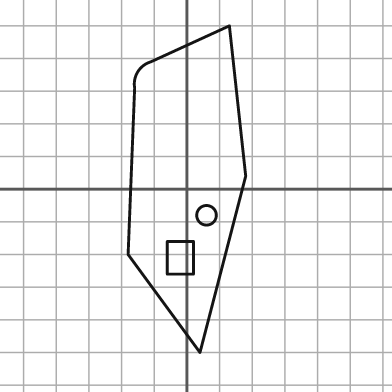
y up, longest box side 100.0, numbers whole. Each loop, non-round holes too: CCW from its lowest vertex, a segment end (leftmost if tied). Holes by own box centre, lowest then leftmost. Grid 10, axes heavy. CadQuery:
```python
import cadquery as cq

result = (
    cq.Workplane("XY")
    .moveTo(4.0, -50.0)
    .lineTo(18.0, 4.0)
    .lineTo(13.0, 50.0)
    .lineTo(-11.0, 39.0)
    .threePointArc((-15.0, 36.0), (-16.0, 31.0))
    .lineTo(-18.0, -20.0)
    .close()
    .moveTo(-6.0, -26.0)
    .lineTo(2.0, -26.0)
    .lineTo(2.0, -16.0)
    .lineTo(-6.0, -16.0)
    .close()
    .moveTo(6.0, -8.0)
    .circle(3.0)
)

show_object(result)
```